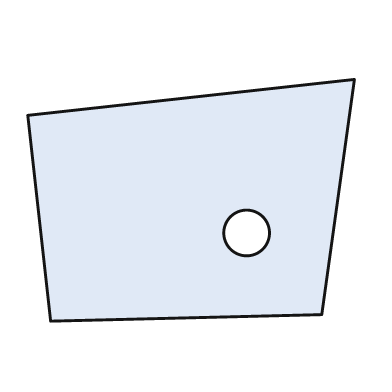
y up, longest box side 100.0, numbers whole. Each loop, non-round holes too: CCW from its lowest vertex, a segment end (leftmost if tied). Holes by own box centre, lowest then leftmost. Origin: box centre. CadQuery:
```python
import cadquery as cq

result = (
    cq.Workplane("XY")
    .moveTo(-43.0, -37.0)
    .lineTo(40.0, -35.0)
    .lineTo(50.0, 37.0)
    .lineTo(-50.0, 26.0)
    .close()
    .moveTo(17.0, -10.0)
    .circle(7.0)
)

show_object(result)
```